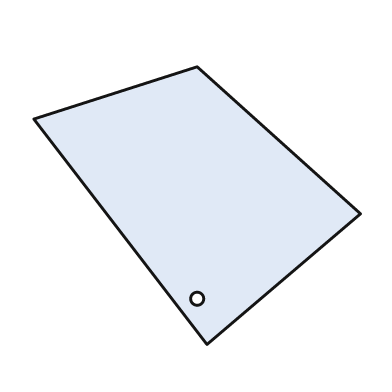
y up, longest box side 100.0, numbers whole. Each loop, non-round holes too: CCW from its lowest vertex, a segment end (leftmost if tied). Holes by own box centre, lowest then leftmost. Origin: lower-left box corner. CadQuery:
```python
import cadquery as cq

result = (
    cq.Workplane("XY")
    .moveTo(53.0, 0.0)
    .lineTo(100.0, 40.0)
    .lineTo(50.0, 85.0)
    .lineTo(0.0, 69.0)
    .close()
    .moveTo(50.0, 14.0)
    .circle(2.0)
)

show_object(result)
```